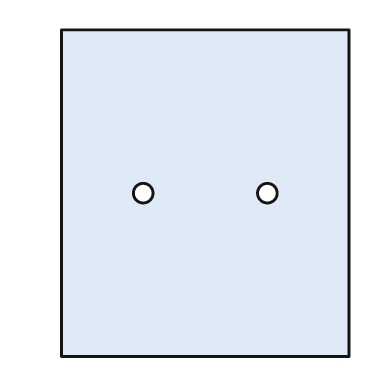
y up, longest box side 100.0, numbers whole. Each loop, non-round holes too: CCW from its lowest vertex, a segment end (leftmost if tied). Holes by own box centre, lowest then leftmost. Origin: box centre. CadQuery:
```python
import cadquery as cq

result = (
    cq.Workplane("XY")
    .moveTo(-44.0, -50.0)
    .lineTo(44.0, -50.0)
    .lineTo(44.0, 50.0)
    .lineTo(-44.0, 50.0)
    .close()
    .moveTo(-19.0, 0.0)
    .circle(3.0)
    .moveTo(19.0, 0.0)
    .circle(3.0)
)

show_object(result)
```